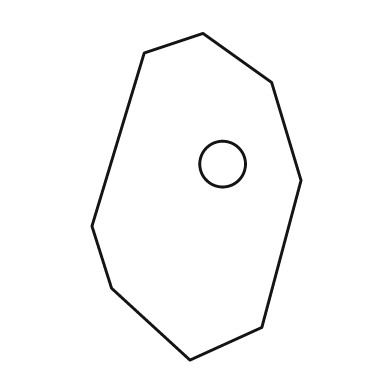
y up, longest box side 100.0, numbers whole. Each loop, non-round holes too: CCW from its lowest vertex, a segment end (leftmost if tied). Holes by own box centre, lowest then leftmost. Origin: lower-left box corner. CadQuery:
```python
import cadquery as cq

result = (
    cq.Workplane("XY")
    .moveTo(30.0, 0.0)
    .lineTo(52.0, 10.0)
    .lineTo(64.0, 55.0)
    .lineTo(55.0, 85.0)
    .lineTo(34.0, 100.0)
    .lineTo(16.0, 94.0)
    .lineTo(0.0, 41.0)
    .lineTo(6.0, 22.0)
    .close()
    .moveTo(40.0, 60.0)
    .circle(7.0)
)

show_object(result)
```